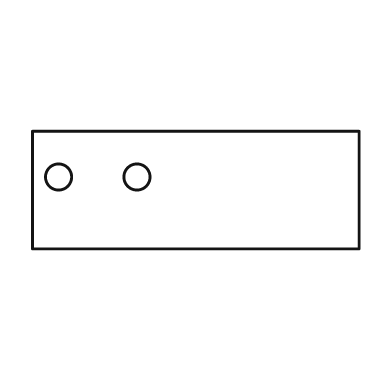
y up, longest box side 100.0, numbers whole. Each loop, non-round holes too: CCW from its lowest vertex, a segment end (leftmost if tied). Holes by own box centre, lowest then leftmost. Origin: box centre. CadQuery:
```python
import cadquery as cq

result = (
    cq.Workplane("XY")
    .moveTo(-50.0, -18.0)
    .lineTo(50.0, -18.0)
    .lineTo(50.0, 18.0)
    .lineTo(-50.0, 18.0)
    .close()
    .moveTo(-42.0, 4.0)
    .circle(4.0)
    .moveTo(-18.0, 4.0)
    .circle(4.0)
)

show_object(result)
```